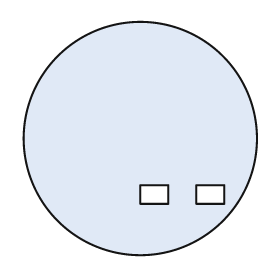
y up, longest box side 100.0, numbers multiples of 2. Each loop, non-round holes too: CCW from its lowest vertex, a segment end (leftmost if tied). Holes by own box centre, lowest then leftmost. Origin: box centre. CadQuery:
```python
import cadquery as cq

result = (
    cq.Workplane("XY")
    .moveTo(0.0, 0.0)
    .circle(50.0)
    .moveTo(0.0, -28.0)
    .lineTo(12.0, -28.0)
    .lineTo(12.0, -20.0)
    .lineTo(0.0, -20.0)
    .close()
    .moveTo(24.0, -28.0)
    .lineTo(36.0, -28.0)
    .lineTo(36.0, -20.0)
    .lineTo(24.0, -20.0)
    .close()
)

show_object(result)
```